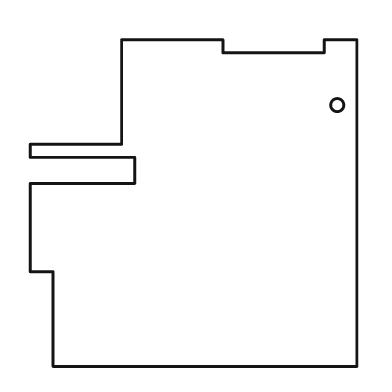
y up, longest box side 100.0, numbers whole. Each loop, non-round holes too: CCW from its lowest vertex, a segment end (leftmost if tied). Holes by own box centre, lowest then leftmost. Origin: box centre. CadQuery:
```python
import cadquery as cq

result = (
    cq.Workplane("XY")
    .moveTo(-43.0, -50.0)
    .lineTo(50.0, -50.0)
    .lineTo(50.0, 50.0)
    .lineTo(40.0, 50.0)
    .lineTo(40.0, 46.0)
    .lineTo(9.0, 46.0)
    .lineTo(9.0, 50.0)
    .lineTo(-22.0, 50.0)
    .lineTo(-22.0, 18.0)
    .lineTo(-50.0, 18.0)
    .lineTo(-50.0, 14.0)
    .lineTo(-18.0, 14.0)
    .lineTo(-18.0, 6.0)
    .lineTo(-50.0, 6.0)
    .lineTo(-50.0, -21.0)
    .lineTo(-43.0, -21.0)
    .close()
    .moveTo(44.0, 30.0)
    .circle(2.0)
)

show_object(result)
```